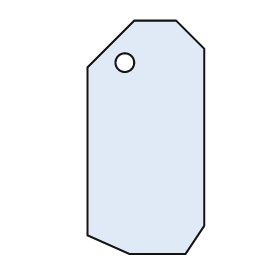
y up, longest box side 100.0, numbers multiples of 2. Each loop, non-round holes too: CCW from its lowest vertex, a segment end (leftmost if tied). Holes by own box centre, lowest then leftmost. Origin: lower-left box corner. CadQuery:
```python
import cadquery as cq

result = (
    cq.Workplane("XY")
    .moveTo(18.0, 0.0)
    .lineTo(42.0, 0.0)
    .lineTo(50.0, 12.0)
    .lineTo(50.0, 88.0)
    .lineTo(38.0, 100.0)
    .lineTo(20.0, 100.0)
    .lineTo(0.0, 80.0)
    .lineTo(0.0, 8.0)
    .close()
    .moveTo(16.0, 82.0)
    .circle(4.0)
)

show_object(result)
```